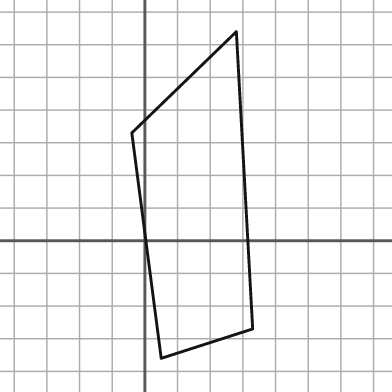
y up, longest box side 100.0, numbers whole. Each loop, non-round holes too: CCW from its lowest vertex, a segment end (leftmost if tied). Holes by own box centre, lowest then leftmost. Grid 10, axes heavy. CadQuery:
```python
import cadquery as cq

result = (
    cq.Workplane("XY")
    .moveTo(5.0, -36.0)
    .lineTo(33.0, -27.0)
    .lineTo(28.0, 64.0)
    .lineTo(-4.0, 33.0)
    .close()
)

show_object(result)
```